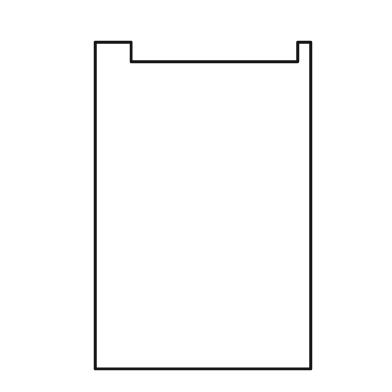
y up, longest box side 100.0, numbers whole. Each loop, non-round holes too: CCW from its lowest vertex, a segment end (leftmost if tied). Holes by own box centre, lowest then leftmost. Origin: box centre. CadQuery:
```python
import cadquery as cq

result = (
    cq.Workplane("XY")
    .moveTo(-33.0, -50.0)
    .lineTo(33.0, -50.0)
    .lineTo(33.0, 50.0)
    .lineTo(29.0, 50.0)
    .lineTo(29.0, 44.0)
    .lineTo(-22.0, 44.0)
    .lineTo(-22.0, 50.0)
    .lineTo(-33.0, 50.0)
    .close()
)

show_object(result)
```